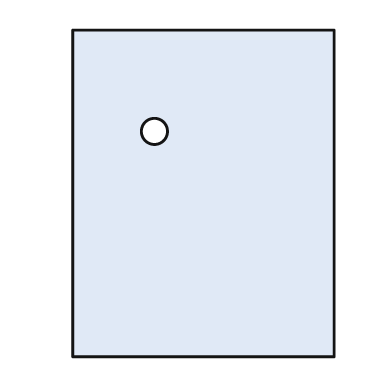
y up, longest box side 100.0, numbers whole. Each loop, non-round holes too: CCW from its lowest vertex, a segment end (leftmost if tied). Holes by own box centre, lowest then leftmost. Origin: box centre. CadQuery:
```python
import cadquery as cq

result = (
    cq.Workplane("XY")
    .moveTo(-40.0, -50.0)
    .lineTo(40.0, -50.0)
    .lineTo(40.0, 50.0)
    .lineTo(-40.0, 50.0)
    .close()
    .moveTo(-15.0, 19.0)
    .circle(4.0)
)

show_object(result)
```